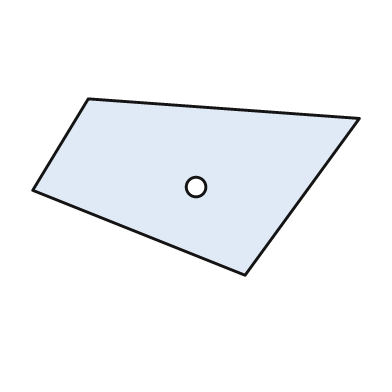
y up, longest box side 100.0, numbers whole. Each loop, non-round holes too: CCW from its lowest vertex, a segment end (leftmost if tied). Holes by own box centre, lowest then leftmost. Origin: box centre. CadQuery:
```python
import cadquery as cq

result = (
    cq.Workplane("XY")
    .moveTo(15.0, -27.0)
    .lineTo(50.0, 21.0)
    .lineTo(-33.0, 27.0)
    .lineTo(-50.0, -1.0)
    .close()
    .moveTo(0.0, 0.0)
    .circle(3.0)
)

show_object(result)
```